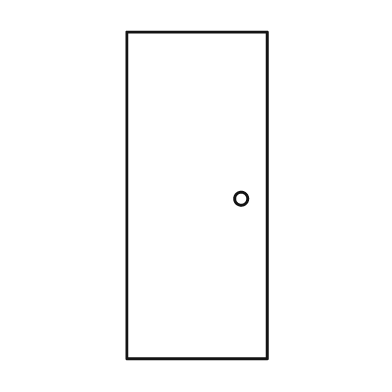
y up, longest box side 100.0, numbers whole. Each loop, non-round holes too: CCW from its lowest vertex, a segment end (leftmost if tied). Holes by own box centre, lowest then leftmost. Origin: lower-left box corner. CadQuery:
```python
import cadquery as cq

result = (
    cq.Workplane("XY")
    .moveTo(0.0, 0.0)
    .lineTo(43.0, 0.0)
    .lineTo(43.0, 100.0)
    .lineTo(0.0, 100.0)
    .close()
    .moveTo(35.0, 49.0)
    .circle(2.0)
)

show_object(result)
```